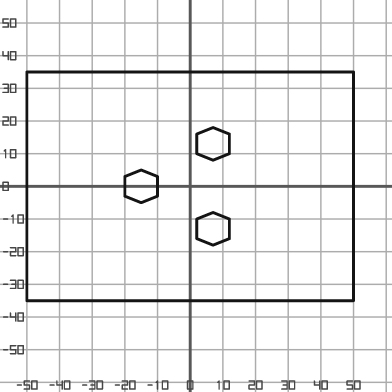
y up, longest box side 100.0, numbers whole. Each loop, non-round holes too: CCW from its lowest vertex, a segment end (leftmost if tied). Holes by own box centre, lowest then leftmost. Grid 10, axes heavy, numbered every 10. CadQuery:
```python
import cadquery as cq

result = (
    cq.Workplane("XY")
    .moveTo(-50.0, -35.0)
    .lineTo(50.0, -35.0)
    .lineTo(50.0, 35.0)
    .lineTo(-50.0, 35.0)
    .close()
    .moveTo(7.0, -18.0)
    .lineTo(12.0, -16.0)
    .lineTo(12.0, -10.0)
    .lineTo(7.0, -8.0)
    .lineTo(2.0, -10.0)
    .lineTo(2.0, -16.0)
    .close()
    .moveTo(-15.0, -5.0)
    .lineTo(-10.0, -3.0)
    .lineTo(-10.0, 3.0)
    .lineTo(-15.0, 5.0)
    .lineTo(-20.0, 3.0)
    .lineTo(-20.0, -3.0)
    .close()
    .moveTo(7.0, 8.0)
    .lineTo(12.0, 10.0)
    .lineTo(12.0, 16.0)
    .lineTo(7.0, 18.0)
    .lineTo(2.0, 16.0)
    .lineTo(2.0, 10.0)
    .close()
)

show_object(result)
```